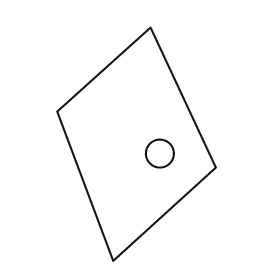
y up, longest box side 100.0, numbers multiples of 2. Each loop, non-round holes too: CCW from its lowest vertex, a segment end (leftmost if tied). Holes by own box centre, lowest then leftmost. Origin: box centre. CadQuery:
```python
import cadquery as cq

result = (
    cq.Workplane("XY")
    .moveTo(-10.0, -50.0)
    .lineTo(34.0, -10.0)
    .lineTo(6.0, 50.0)
    .lineTo(-34.0, 14.0)
    .close()
    .moveTo(10.0, -4.0)
    .circle(6.0)
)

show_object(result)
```